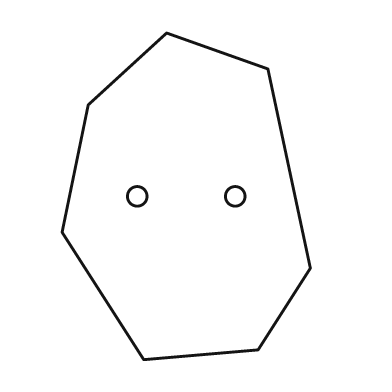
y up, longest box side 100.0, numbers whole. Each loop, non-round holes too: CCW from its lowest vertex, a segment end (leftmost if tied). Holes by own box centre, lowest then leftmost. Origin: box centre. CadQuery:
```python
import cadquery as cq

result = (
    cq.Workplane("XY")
    .moveTo(-13.0, -50.0)
    .lineTo(22.0, -47.0)
    .lineTo(38.0, -22.0)
    .lineTo(25.0, 39.0)
    .lineTo(-6.0, 50.0)
    .lineTo(-30.0, 28.0)
    .lineTo(-38.0, -11.0)
    .close()
    .moveTo(-15.0, 0.0)
    .circle(3.0)
    .moveTo(15.0, 0.0)
    .circle(3.0)
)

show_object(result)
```